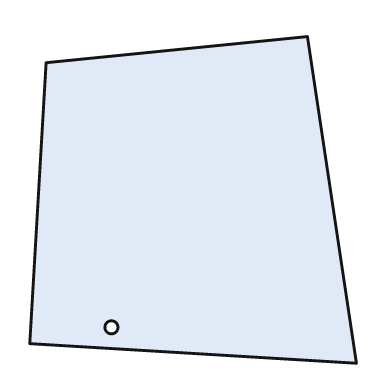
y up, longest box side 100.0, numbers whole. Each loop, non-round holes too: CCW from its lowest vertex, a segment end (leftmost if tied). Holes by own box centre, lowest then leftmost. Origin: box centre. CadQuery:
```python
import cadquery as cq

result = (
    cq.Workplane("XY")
    .moveTo(50.0, -50.0)
    .lineTo(35.0, 50.0)
    .lineTo(-45.0, 42.0)
    .lineTo(-50.0, -44.0)
    .close()
    .moveTo(-25.0, -39.0)
    .circle(2.0)
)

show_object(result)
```